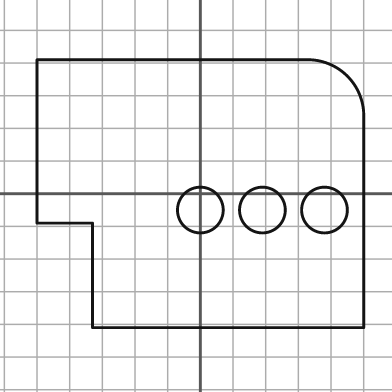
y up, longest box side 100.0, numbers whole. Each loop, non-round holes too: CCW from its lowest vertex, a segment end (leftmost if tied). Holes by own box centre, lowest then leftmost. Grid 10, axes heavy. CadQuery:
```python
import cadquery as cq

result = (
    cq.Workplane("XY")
    .moveTo(-33.0, -41.0)
    .lineTo(50.0, -41.0)
    .lineTo(50.0, 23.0)
    .threePointArc((45.0, 36.0), (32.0, 41.0))
    .lineTo(-50.0, 41.0)
    .lineTo(-50.0, -9.0)
    .lineTo(-33.0, -9.0)
    .close()
    .moveTo(0.0, -5.0)
    .circle(7.0)
    .moveTo(19.0, -5.0)
    .circle(7.0)
    .moveTo(38.0, -5.0)
    .circle(7.0)
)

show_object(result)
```